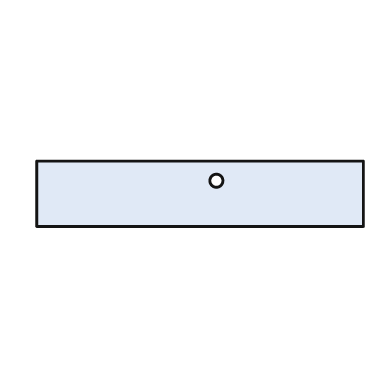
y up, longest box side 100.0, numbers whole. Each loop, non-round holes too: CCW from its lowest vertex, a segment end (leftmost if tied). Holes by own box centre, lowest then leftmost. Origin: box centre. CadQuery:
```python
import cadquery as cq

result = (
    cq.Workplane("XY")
    .moveTo(-50.0, -10.0)
    .lineTo(50.0, -10.0)
    .lineTo(50.0, 10.0)
    .lineTo(-50.0, 10.0)
    .close()
    .moveTo(5.0, 4.0)
    .circle(2.0)
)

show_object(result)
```